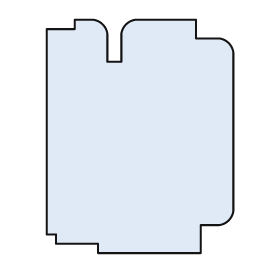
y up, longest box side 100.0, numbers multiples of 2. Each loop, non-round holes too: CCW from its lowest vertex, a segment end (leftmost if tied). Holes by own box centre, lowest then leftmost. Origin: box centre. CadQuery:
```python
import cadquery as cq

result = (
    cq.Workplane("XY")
    .moveTo(-18.0, -50.0)
    .lineTo(26.0, -50.0)
    .lineTo(26.0, -38.0)
    .lineTo(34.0, -38.0)
    .threePointArc((38.0, -36.0), (40.0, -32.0))
    .lineTo(40.0, 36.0)
    .threePointArc((38.0, 40.0), (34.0, 42.0))
    .lineTo(24.0, 42.0)
    .lineTo(24.0, 50.0)
    .lineTo(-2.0, 50.0)
    .threePointArc((-6.0, 48.0), (-8.0, 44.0))
    .lineTo(-8.0, 32.0)
    .lineTo(-14.0, 32.0)
    .lineTo(-14.0, 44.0)
    .threePointArc((-16.0, 48.0), (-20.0, 50.0))
    .lineTo(-28.0, 50.0)
    .lineTo(-28.0, 46.0)
    .lineTo(-40.0, 46.0)
    .lineTo(-40.0, -42.0)
    .lineTo(-36.0, -42.0)
    .lineTo(-36.0, -46.0)
    .lineTo(-18.0, -46.0)
    .close()
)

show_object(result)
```